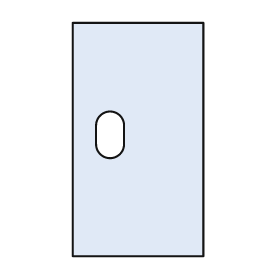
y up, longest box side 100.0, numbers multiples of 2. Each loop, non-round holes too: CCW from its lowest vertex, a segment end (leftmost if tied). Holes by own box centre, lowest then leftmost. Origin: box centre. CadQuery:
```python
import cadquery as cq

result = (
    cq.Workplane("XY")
    .moveTo(-28.0, -50.0)
    .lineTo(28.0, -50.0)
    .lineTo(28.0, 50.0)
    .lineTo(-28.0, 50.0)
    .close()
    .moveTo(-18.0, -2.0)
    .threePointArc((-12.0, -8.0), (-6.0, -2.0))
    .lineTo(-6.0, 6.0)
    .threePointArc((-12.0, 12.0), (-18.0, 6.0))
    .close()
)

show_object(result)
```